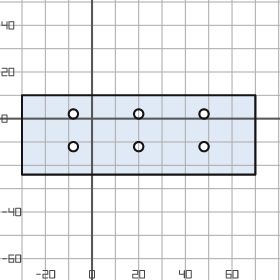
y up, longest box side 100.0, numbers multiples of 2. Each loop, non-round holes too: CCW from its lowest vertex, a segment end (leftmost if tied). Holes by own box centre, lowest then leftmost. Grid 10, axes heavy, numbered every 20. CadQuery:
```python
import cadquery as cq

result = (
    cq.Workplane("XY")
    .moveTo(-30.0, -24.0)
    .lineTo(70.0, -24.0)
    .lineTo(70.0, 10.0)
    .lineTo(-30.0, 10.0)
    .close()
    .moveTo(-8.0, -12.0)
    .circle(2.0)
    .moveTo(20.0, -12.0)
    .circle(2.0)
    .moveTo(48.0, -12.0)
    .circle(2.0)
    .moveTo(-8.0, 2.0)
    .circle(2.0)
    .moveTo(20.0, 2.0)
    .circle(2.0)
    .moveTo(48.0, 2.0)
    .circle(2.0)
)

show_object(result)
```